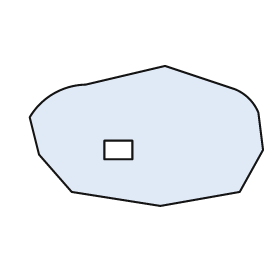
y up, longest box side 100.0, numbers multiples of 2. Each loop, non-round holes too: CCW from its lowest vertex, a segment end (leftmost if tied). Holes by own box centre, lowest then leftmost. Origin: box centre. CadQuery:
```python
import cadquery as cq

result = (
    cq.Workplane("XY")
    .moveTo(6.0, -30.0)
    .lineTo(40.0, -24.0)
    .lineTo(50.0, -6.0)
    .lineTo(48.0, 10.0)
    .threePointArc((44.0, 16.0), (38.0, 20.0))
    .lineTo(8.0, 30.0)
    .lineTo(-26.0, 22.0)
    .threePointArc((-40.0, 18.0), (-50.0, 8.0))
    .lineTo(-46.0, -8.0)
    .lineTo(-32.0, -24.0)
    .close()
    .moveTo(-18.0, -10.0)
    .lineTo(-6.0, -10.0)
    .lineTo(-6.0, -2.0)
    .lineTo(-18.0, -2.0)
    .close()
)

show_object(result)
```